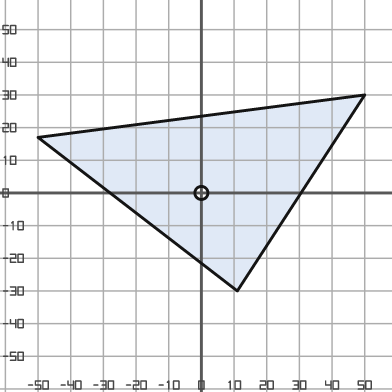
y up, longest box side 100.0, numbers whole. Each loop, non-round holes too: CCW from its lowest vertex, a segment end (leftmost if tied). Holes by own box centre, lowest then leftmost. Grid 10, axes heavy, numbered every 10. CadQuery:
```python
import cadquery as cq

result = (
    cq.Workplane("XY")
    .moveTo(11.0, -30.0)
    .lineTo(50.0, 30.0)
    .lineTo(-50.0, 17.0)
    .close()
    .moveTo(0.0, 0.0)
    .circle(2.0)
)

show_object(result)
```